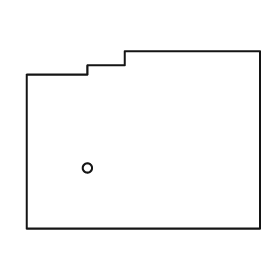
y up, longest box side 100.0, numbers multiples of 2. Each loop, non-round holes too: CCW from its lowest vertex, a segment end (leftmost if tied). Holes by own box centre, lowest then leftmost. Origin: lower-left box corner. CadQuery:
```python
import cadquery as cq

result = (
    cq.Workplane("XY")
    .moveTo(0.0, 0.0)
    .lineTo(100.0, 0.0)
    .lineTo(100.0, 76.0)
    .lineTo(42.0, 76.0)
    .lineTo(42.0, 70.0)
    .lineTo(26.0, 70.0)
    .lineTo(26.0, 66.0)
    .lineTo(0.0, 66.0)
    .close()
    .moveTo(26.0, 26.0)
    .circle(2.0)
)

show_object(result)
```